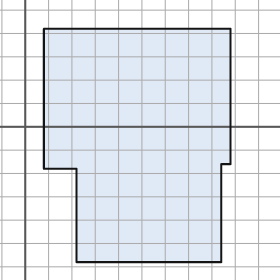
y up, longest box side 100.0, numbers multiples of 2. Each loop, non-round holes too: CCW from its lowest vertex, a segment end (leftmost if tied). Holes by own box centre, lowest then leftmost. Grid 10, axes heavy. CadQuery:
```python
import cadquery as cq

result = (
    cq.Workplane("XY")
    .moveTo(22.0, -58.0)
    .lineTo(84.0, -58.0)
    .lineTo(84.0, -16.0)
    .lineTo(88.0, -16.0)
    .lineTo(88.0, 42.0)
    .lineTo(8.0, 42.0)
    .lineTo(8.0, -18.0)
    .lineTo(22.0, -18.0)
    .close()
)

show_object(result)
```